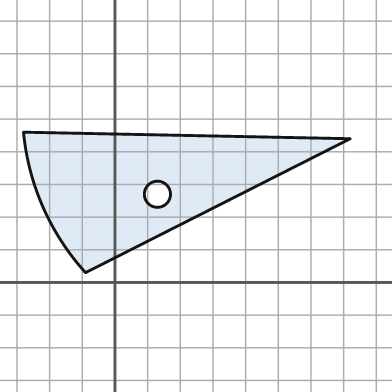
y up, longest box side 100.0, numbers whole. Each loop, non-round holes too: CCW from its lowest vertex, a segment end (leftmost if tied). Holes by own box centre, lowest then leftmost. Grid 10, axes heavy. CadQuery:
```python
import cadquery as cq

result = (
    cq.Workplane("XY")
    .moveTo(-9.0, 3.0)
    .lineTo(72.0, 44.0)
    .lineTo(-28.0, 46.0)
    .threePointArc((-22.0, 23.0), (-9.0, 3.0))
    .close()
    .moveTo(13.0, 27.0)
    .circle(4.0)
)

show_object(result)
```